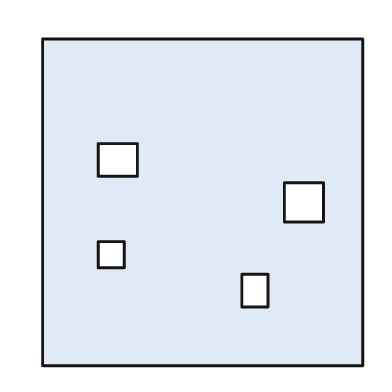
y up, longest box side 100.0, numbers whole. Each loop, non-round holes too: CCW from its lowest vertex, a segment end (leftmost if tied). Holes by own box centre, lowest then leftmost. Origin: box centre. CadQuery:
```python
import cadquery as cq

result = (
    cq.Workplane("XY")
    .moveTo(-49.0, -50.0)
    .lineTo(49.0, -50.0)
    .lineTo(49.0, 50.0)
    .lineTo(-49.0, 50.0)
    .close()
    .moveTo(12.0, -32.0)
    .lineTo(20.0, -32.0)
    .lineTo(20.0, -22.0)
    .lineTo(12.0, -22.0)
    .close()
    .moveTo(-32.0, -20.0)
    .lineTo(-24.0, -20.0)
    .lineTo(-24.0, -12.0)
    .lineTo(-32.0, -12.0)
    .close()
    .moveTo(25.0, -6.0)
    .lineTo(37.0, -6.0)
    .lineTo(37.0, 6.0)
    .lineTo(25.0, 6.0)
    .close()
    .moveTo(-32.0, 8.0)
    .lineTo(-20.0, 8.0)
    .lineTo(-20.0, 18.0)
    .lineTo(-32.0, 18.0)
    .close()
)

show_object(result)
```